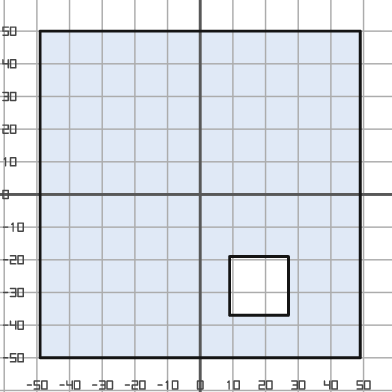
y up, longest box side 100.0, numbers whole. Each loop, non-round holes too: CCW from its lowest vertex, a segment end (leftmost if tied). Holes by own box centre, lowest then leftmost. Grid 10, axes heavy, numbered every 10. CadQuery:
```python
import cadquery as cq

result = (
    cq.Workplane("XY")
    .moveTo(-49.0, -50.0)
    .lineTo(49.0, -50.0)
    .lineTo(49.0, 50.0)
    .lineTo(-49.0, 50.0)
    .close()
    .moveTo(9.0, -37.0)
    .lineTo(27.0, -37.0)
    .lineTo(27.0, -19.0)
    .lineTo(9.0, -19.0)
    .close()
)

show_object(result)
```